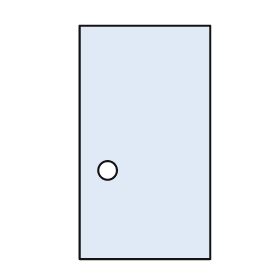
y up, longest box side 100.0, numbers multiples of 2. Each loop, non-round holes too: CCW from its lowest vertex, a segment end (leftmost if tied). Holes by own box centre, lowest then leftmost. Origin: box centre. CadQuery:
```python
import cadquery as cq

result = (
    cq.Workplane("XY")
    .moveTo(-28.0, -50.0)
    .lineTo(28.0, -50.0)
    .lineTo(28.0, 50.0)
    .lineTo(-28.0, 50.0)
    .close()
    .moveTo(-16.0, -12.0)
    .circle(4.0)
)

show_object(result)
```